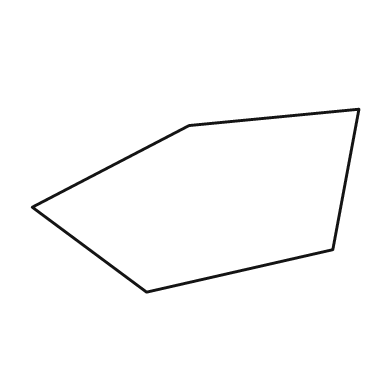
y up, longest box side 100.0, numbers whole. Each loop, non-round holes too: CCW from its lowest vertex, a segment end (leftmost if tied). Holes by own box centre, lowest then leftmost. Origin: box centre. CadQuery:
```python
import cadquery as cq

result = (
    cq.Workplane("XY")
    .moveTo(-15.0, -28.0)
    .lineTo(42.0, -15.0)
    .lineTo(50.0, 28.0)
    .lineTo(-2.0, 23.0)
    .lineTo(-50.0, -2.0)
    .close()
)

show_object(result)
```